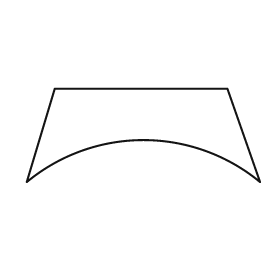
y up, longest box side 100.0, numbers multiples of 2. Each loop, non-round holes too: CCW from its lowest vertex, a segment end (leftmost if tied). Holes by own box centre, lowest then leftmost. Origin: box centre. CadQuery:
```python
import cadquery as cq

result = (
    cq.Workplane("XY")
    .moveTo(-50.0, -20.0)
    .threePointArc((0.0, -2.0), (50.0, -20.0))
    .lineTo(36.0, 20.0)
    .lineTo(-38.0, 20.0)
    .close()
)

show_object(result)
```